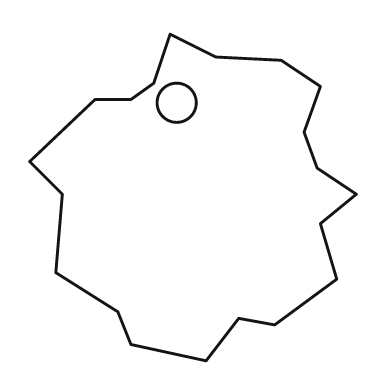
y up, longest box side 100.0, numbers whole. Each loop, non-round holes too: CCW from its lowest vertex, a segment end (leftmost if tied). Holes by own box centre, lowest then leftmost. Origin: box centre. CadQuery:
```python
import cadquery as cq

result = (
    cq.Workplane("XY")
    .moveTo(4.0, -50.0)
    .lineTo(14.0, -37.0)
    .lineTo(25.0, -39.0)
    .lineTo(44.0, -25.0)
    .lineTo(39.0, -8.0)
    .lineTo(50.0, 1.0)
    .lineTo(38.0, 9.0)
    .lineTo(34.0, 20.0)
    .lineTo(39.0, 34.0)
    .lineTo(27.0, 42.0)
    .lineTo(7.0, 43.0)
    .lineTo(-7.0, 50.0)
    .lineTo(-12.0, 35.0)
    .lineTo(-19.0, 30.0)
    .lineTo(-30.0, 30.0)
    .lineTo(-50.0, 11.0)
    .lineTo(-40.0, 1.0)
    .lineTo(-42.0, -23.0)
    .lineTo(-23.0, -35.0)
    .lineTo(-19.0, -45.0)
    .close()
    .moveTo(-5.0, 29.0)
    .circle(6.0)
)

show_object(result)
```